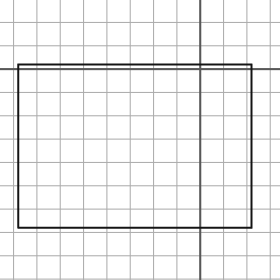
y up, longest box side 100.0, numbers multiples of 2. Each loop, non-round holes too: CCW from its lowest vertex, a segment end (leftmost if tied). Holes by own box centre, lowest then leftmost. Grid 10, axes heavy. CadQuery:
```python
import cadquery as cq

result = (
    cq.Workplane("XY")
    .moveTo(-78.0, -68.0)
    .lineTo(22.0, -68.0)
    .lineTo(22.0, 2.0)
    .lineTo(-78.0, 2.0)
    .close()
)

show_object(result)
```